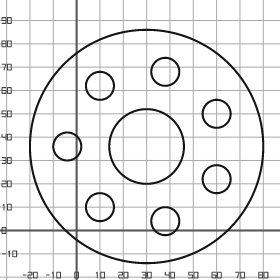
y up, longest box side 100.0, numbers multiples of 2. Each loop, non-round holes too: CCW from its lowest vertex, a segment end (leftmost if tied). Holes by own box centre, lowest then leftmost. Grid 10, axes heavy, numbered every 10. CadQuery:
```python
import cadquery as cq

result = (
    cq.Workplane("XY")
    .moveTo(30.0, 36.0)
    .circle(50.0)
    .moveTo(38.0, 4.0)
    .circle(6.0)
    .moveTo(10.0, 10.0)
    .circle(6.0)
    .moveTo(60.0, 22.0)
    .circle(6.0)
    .moveTo(-4.0, 36.0)
    .circle(6.0)
    .moveTo(30.0, 36.0)
    .circle(16.0)
    .moveTo(60.0, 50.0)
    .circle(6.0)
    .moveTo(10.0, 62.0)
    .circle(6.0)
    .moveTo(38.0, 68.0)
    .circle(6.0)
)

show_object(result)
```